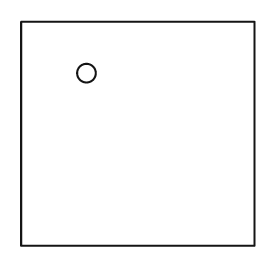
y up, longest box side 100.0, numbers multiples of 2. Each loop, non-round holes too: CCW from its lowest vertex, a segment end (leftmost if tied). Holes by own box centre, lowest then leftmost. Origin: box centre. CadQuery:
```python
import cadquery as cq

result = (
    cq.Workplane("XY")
    .moveTo(-50.0, -48.0)
    .lineTo(50.0, -48.0)
    .lineTo(50.0, 48.0)
    .lineTo(-50.0, 48.0)
    .close()
    .moveTo(-22.0, 26.0)
    .circle(4.0)
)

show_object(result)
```